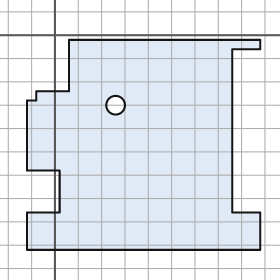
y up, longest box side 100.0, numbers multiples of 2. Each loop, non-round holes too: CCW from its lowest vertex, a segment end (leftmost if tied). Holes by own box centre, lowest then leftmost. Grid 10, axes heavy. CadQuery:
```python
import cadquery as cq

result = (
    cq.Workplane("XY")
    .moveTo(-12.0, -92.0)
    .lineTo(88.0, -92.0)
    .lineTo(88.0, -76.0)
    .lineTo(76.0, -76.0)
    .lineTo(76.0, -6.0)
    .lineTo(88.0, -6.0)
    .lineTo(88.0, -2.0)
    .lineTo(6.0, -2.0)
    .lineTo(6.0, -24.0)
    .lineTo(-8.0, -24.0)
    .lineTo(-8.0, -28.0)
    .lineTo(-12.0, -28.0)
    .lineTo(-12.0, -58.0)
    .lineTo(2.0, -58.0)
    .lineTo(2.0, -76.0)
    .lineTo(-12.0, -76.0)
    .close()
    .moveTo(26.0, -30.0)
    .circle(4.0)
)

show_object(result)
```